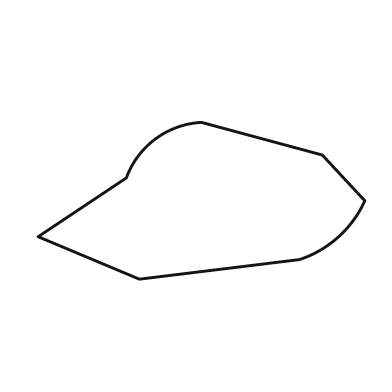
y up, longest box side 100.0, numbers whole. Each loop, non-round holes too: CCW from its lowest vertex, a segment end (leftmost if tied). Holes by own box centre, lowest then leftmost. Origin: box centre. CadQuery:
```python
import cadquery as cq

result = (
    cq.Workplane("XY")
    .moveTo(-19.0, -24.0)
    .lineTo(30.0, -18.0)
    .threePointArc((42.0, -11.0), (50.0, 0.0))
    .lineTo(37.0, 14.0)
    .lineTo(0.0, 24.0)
    .threePointArc((-14.0, 19.0), (-23.0, 7.0))
    .lineTo(-50.0, -11.0)
    .close()
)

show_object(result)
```